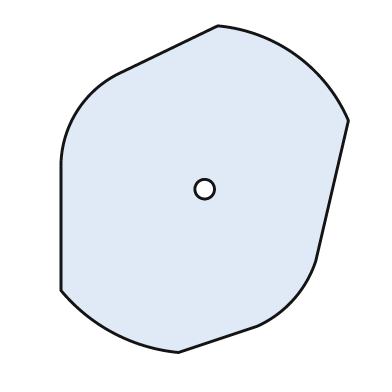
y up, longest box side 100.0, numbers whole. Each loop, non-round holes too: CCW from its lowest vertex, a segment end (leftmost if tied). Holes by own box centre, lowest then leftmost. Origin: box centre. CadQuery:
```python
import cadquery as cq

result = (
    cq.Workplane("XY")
    .moveTo(-8.0, -50.0)
    .lineTo(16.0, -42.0)
    .threePointArc((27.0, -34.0), (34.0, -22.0))
    .lineTo(44.0, 21.0)
    .threePointArc((28.0, 41.0), (4.0, 50.0))
    .lineTo(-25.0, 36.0)
    .threePointArc((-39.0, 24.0), (-44.0, 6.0))
    .lineTo(-44.0, -31.0)
    .threePointArc((-28.0, -44.0), (-8.0, -50.0))
    .close()
    .moveTo(0.0, 0.0)
    .circle(3.0)
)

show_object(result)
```